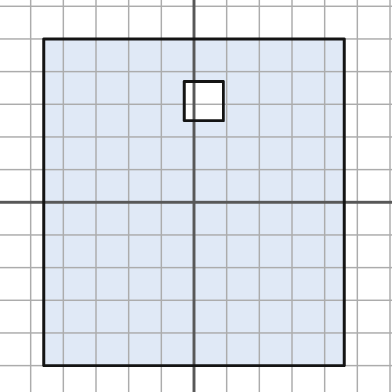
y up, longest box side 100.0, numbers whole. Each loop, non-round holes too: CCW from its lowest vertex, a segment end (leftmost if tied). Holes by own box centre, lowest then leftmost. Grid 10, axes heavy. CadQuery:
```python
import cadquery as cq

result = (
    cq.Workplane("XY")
    .moveTo(-46.0, -50.0)
    .lineTo(46.0, -50.0)
    .lineTo(46.0, 50.0)
    .lineTo(-46.0, 50.0)
    .close()
    .moveTo(-3.0, 25.0)
    .lineTo(9.0, 25.0)
    .lineTo(9.0, 37.0)
    .lineTo(-3.0, 37.0)
    .close()
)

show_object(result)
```